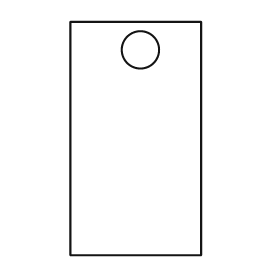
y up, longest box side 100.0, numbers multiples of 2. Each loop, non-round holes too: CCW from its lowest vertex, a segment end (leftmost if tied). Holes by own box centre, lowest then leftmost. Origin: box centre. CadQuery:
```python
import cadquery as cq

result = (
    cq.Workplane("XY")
    .moveTo(-28.0, -50.0)
    .lineTo(28.0, -50.0)
    .lineTo(28.0, 50.0)
    .lineTo(-28.0, 50.0)
    .close()
    .moveTo(2.0, 38.0)
    .circle(8.0)
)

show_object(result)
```